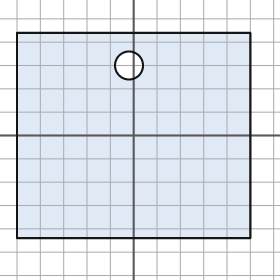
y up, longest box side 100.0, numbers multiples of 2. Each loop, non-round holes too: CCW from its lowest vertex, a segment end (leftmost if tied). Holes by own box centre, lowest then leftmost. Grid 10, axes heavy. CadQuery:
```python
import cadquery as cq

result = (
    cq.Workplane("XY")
    .moveTo(-50.0, -44.0)
    .lineTo(50.0, -44.0)
    .lineTo(50.0, 44.0)
    .lineTo(-50.0, 44.0)
    .close()
    .moveTo(-2.0, 30.0)
    .circle(6.0)
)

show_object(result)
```